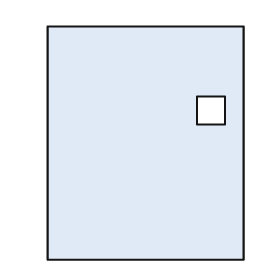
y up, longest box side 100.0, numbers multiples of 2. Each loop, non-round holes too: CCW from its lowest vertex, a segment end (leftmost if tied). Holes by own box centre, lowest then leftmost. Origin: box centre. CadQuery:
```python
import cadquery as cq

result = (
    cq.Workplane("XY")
    .moveTo(-42.0, -50.0)
    .lineTo(42.0, -50.0)
    .lineTo(42.0, 50.0)
    .lineTo(-42.0, 50.0)
    .close()
    .moveTo(22.0, 8.0)
    .lineTo(34.0, 8.0)
    .lineTo(34.0, 20.0)
    .lineTo(22.0, 20.0)
    .close()
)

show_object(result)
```